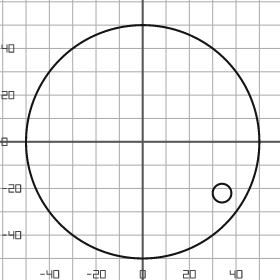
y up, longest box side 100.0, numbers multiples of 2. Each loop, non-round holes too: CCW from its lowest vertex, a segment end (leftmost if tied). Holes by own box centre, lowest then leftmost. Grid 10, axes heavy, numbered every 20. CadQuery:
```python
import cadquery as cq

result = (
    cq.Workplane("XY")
    .moveTo(0.0, 0.0)
    .circle(50.0)
    .moveTo(34.0, -22.0)
    .circle(4.0)
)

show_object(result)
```